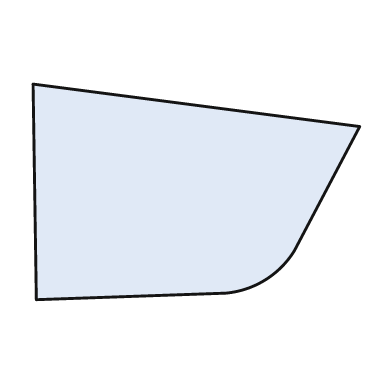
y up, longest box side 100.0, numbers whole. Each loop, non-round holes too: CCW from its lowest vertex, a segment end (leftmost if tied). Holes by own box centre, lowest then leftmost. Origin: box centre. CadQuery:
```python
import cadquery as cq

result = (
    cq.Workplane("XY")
    .moveTo(-49.0, -33.0)
    .lineTo(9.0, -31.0)
    .threePointArc((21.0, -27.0), (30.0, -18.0))
    .lineTo(50.0, 20.0)
    .lineTo(-50.0, 33.0)
    .close()
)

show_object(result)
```